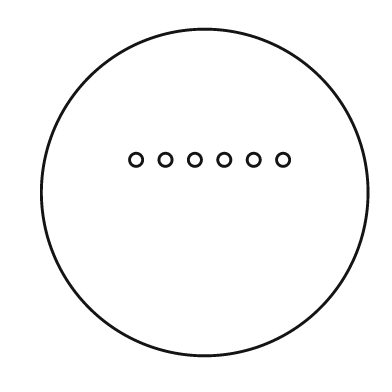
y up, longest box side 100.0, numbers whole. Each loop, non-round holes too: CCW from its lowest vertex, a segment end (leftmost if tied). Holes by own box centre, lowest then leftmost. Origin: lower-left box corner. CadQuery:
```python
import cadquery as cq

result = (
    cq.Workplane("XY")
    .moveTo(50.0, 50.0)
    .circle(50.0)
    .moveTo(29.0, 60.0)
    .circle(2.0)
    .moveTo(38.0, 60.0)
    .circle(2.0)
    .moveTo(47.0, 60.0)
    .circle(2.0)
    .moveTo(56.0, 60.0)
    .circle(2.0)
    .moveTo(65.0, 60.0)
    .circle(2.0)
    .moveTo(74.0, 60.0)
    .circle(2.0)
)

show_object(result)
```